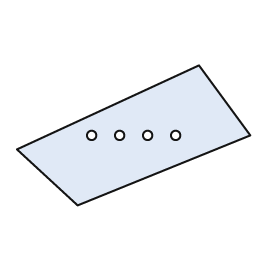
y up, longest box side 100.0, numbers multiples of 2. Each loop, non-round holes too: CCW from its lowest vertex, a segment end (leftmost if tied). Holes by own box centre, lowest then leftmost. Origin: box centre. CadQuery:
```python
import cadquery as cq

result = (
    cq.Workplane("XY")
    .moveTo(-24.0, -30.0)
    .lineTo(50.0, 0.0)
    .lineTo(28.0, 30.0)
    .lineTo(-50.0, -6.0)
    .close()
    .moveTo(-18.0, 0.0)
    .circle(2.0)
    .moveTo(-6.0, 0.0)
    .circle(2.0)
    .moveTo(6.0, 0.0)
    .circle(2.0)
    .moveTo(18.0, 0.0)
    .circle(2.0)
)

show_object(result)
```